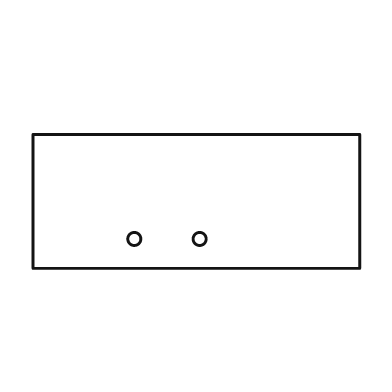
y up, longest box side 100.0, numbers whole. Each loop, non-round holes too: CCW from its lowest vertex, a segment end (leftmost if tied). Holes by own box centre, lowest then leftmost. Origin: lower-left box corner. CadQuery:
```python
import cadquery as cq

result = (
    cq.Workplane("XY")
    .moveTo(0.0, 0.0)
    .lineTo(100.0, 0.0)
    .lineTo(100.0, 41.0)
    .lineTo(0.0, 41.0)
    .close()
    .moveTo(31.0, 9.0)
    .circle(2.0)
    .moveTo(51.0, 9.0)
    .circle(2.0)
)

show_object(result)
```